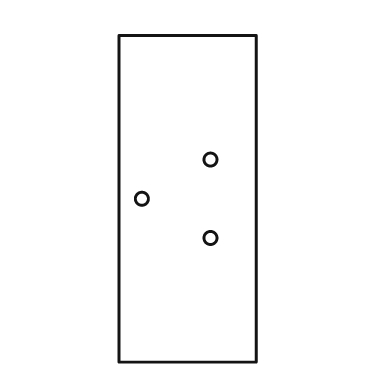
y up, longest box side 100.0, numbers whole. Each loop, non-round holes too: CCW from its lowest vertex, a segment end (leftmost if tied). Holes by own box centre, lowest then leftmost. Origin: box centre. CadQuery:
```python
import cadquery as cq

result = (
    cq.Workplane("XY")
    .moveTo(-21.0, -50.0)
    .lineTo(21.0, -50.0)
    .lineTo(21.0, 50.0)
    .lineTo(-21.0, 50.0)
    .close()
    .moveTo(7.0, -12.0)
    .circle(2.0)
    .moveTo(-14.0, 0.0)
    .circle(2.0)
    .moveTo(7.0, 12.0)
    .circle(2.0)
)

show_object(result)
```